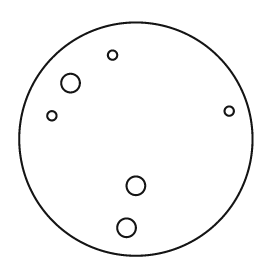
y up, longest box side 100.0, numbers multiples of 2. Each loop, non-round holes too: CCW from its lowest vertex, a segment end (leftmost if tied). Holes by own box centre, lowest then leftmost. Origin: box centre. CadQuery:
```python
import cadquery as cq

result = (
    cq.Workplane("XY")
    .moveTo(0.0, 0.0)
    .circle(50.0)
    .moveTo(-4.0, -38.0)
    .circle(4.0)
    .moveTo(0.0, -20.0)
    .circle(4.0)
    .moveTo(-36.0, 10.0)
    .circle(2.0)
    .moveTo(40.0, 12.0)
    .circle(2.0)
    .moveTo(-28.0, 24.0)
    .circle(4.0)
    .moveTo(-10.0, 36.0)
    .circle(2.0)
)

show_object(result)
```